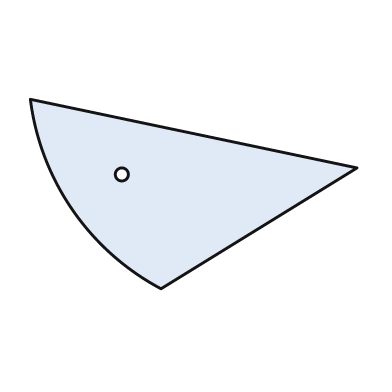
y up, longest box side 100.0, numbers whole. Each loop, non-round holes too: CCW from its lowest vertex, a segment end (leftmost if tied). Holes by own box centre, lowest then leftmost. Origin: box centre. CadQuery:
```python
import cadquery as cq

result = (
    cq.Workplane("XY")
    .moveTo(-10.0, -29.0)
    .lineTo(50.0, 8.0)
    .lineTo(-50.0, 29.0)
    .threePointArc((-37.0, -5.0), (-10.0, -29.0))
    .close()
    .moveTo(-22.0, 6.0)
    .circle(2.0)
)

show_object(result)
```